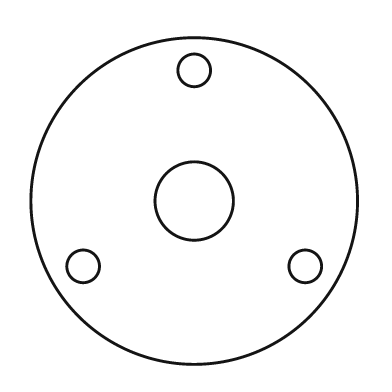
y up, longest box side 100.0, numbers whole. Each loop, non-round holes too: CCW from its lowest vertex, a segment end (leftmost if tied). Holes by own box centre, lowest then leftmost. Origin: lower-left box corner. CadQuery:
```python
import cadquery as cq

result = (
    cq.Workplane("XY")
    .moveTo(50.0, 50.0)
    .circle(50.0)
    .moveTo(16.0, 30.0)
    .circle(5.0)
    .moveTo(84.0, 30.0)
    .circle(5.0)
    .moveTo(50.0, 50.0)
    .circle(12.0)
    .moveTo(50.0, 90.0)
    .circle(5.0)
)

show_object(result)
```